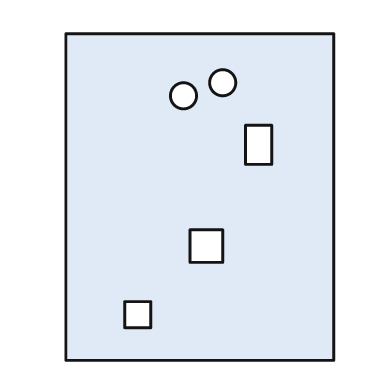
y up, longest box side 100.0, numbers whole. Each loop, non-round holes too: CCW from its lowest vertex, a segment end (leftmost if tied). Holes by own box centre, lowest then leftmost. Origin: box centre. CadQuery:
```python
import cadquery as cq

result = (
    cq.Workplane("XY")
    .moveTo(-41.0, -50.0)
    .lineTo(41.0, -50.0)
    .lineTo(41.0, 50.0)
    .lineTo(-41.0, 50.0)
    .close()
    .moveTo(-23.0, -40.0)
    .lineTo(-15.0, -40.0)
    .lineTo(-15.0, -32.0)
    .lineTo(-23.0, -32.0)
    .close()
    .moveTo(-3.0, -20.0)
    .lineTo(7.0, -20.0)
    .lineTo(7.0, -10.0)
    .lineTo(-3.0, -10.0)
    .close()
    .moveTo(14.0, 10.0)
    .lineTo(22.0, 10.0)
    .lineTo(22.0, 22.0)
    .lineTo(14.0, 22.0)
    .close()
    .moveTo(-5.0, 31.0)
    .circle(4.0)
    .moveTo(7.0, 35.0)
    .circle(4.0)
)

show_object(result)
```